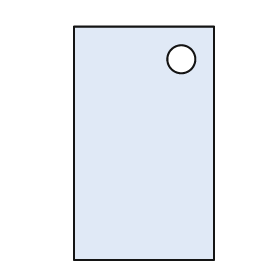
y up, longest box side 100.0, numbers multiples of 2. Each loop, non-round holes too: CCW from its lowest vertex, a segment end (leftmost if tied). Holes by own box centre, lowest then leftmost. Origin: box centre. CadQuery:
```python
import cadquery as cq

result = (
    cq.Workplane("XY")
    .moveTo(-30.0, -50.0)
    .lineTo(30.0, -50.0)
    .lineTo(30.0, 50.0)
    .lineTo(-30.0, 50.0)
    .close()
    .moveTo(16.0, 36.0)
    .circle(6.0)
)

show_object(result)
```